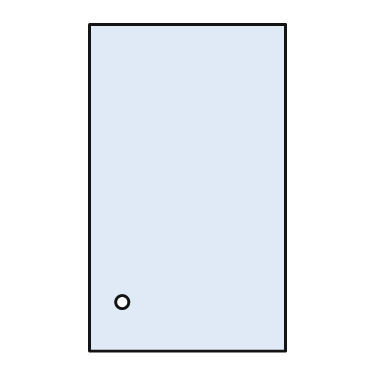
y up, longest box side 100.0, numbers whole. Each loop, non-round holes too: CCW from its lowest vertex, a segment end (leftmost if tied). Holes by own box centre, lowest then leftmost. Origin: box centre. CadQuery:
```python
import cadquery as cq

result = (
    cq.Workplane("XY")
    .moveTo(-30.0, -50.0)
    .lineTo(30.0, -50.0)
    .lineTo(30.0, 50.0)
    .lineTo(-30.0, 50.0)
    .close()
    .moveTo(-20.0, -35.0)
    .circle(2.0)
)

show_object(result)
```